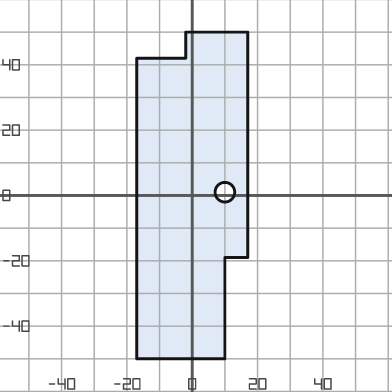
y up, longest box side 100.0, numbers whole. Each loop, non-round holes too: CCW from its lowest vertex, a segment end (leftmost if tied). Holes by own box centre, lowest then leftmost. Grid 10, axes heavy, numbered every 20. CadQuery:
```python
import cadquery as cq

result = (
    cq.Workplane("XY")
    .moveTo(-17.0, -50.0)
    .lineTo(10.0, -50.0)
    .lineTo(10.0, -19.0)
    .lineTo(17.0, -19.0)
    .lineTo(17.0, 50.0)
    .lineTo(-2.0, 50.0)
    .lineTo(-2.0, 42.0)
    .lineTo(-17.0, 42.0)
    .close()
    .moveTo(10.0, 1.0)
    .circle(3.0)
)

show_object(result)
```